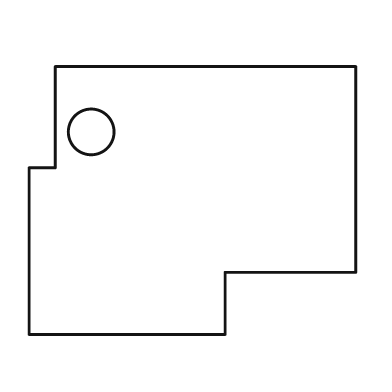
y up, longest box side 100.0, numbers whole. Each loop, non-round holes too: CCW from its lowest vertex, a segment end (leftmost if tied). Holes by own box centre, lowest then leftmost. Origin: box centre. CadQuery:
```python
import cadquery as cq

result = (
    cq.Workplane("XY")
    .moveTo(-50.0, -41.0)
    .lineTo(10.0, -41.0)
    .lineTo(10.0, -22.0)
    .lineTo(50.0, -22.0)
    .lineTo(50.0, 41.0)
    .lineTo(-42.0, 41.0)
    .lineTo(-42.0, 10.0)
    .lineTo(-50.0, 10.0)
    .close()
    .moveTo(-31.0, 21.0)
    .circle(7.0)
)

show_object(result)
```